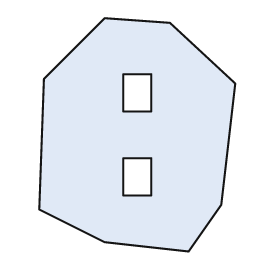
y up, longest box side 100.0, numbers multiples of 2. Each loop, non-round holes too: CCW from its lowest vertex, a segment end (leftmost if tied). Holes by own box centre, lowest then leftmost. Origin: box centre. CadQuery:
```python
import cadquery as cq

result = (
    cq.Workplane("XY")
    .moveTo(22.0, -50.0)
    .lineTo(36.0, -30.0)
    .lineTo(42.0, 22.0)
    .lineTo(14.0, 48.0)
    .lineTo(-14.0, 50.0)
    .lineTo(-40.0, 24.0)
    .lineTo(-42.0, -32.0)
    .lineTo(-14.0, -46.0)
    .close()
    .moveTo(-6.0, -26.0)
    .lineTo(6.0, -26.0)
    .lineTo(6.0, -10.0)
    .lineTo(-6.0, -10.0)
    .close()
    .moveTo(-6.0, 10.0)
    .lineTo(6.0, 10.0)
    .lineTo(6.0, 26.0)
    .lineTo(-6.0, 26.0)
    .close()
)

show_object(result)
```